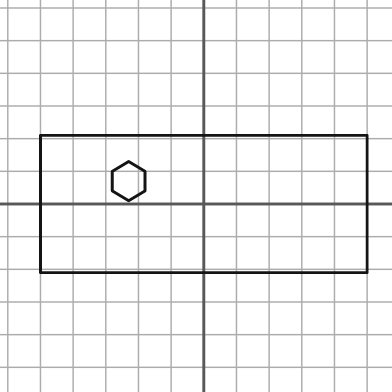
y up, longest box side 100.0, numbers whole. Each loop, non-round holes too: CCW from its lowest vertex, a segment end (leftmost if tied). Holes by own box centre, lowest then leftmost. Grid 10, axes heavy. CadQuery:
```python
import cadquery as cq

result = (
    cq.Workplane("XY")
    .moveTo(-50.0, -21.0)
    .lineTo(50.0, -21.0)
    .lineTo(50.0, 21.0)
    .lineTo(-50.0, 21.0)
    .close()
    .moveTo(-23.0, 1.0)
    .lineTo(-18.0, 4.0)
    .lineTo(-18.0, 10.0)
    .lineTo(-23.0, 13.0)
    .lineTo(-28.0, 10.0)
    .lineTo(-28.0, 4.0)
    .close()
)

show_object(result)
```